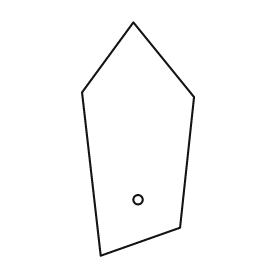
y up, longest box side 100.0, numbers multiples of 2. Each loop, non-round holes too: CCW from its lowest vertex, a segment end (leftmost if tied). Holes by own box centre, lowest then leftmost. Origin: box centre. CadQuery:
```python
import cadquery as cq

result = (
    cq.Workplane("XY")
    .moveTo(-16.0, -50.0)
    .lineTo(18.0, -38.0)
    .lineTo(24.0, 18.0)
    .lineTo(-2.0, 50.0)
    .lineTo(-24.0, 20.0)
    .close()
    .moveTo(0.0, -26.0)
    .circle(2.0)
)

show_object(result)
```